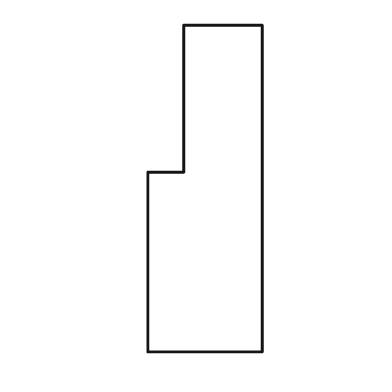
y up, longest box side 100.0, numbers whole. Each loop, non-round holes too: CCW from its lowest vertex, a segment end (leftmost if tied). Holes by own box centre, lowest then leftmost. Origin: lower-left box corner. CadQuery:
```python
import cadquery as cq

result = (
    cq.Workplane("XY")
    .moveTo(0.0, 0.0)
    .lineTo(35.0, 0.0)
    .lineTo(35.0, 100.0)
    .lineTo(11.0, 100.0)
    .lineTo(11.0, 55.0)
    .lineTo(0.0, 55.0)
    .close()
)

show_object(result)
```